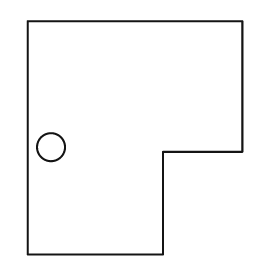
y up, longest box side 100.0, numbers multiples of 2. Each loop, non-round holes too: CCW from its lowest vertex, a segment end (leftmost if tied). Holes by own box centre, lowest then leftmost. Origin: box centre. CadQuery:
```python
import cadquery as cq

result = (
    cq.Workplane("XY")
    .moveTo(-46.0, -50.0)
    .lineTo(12.0, -50.0)
    .lineTo(12.0, -6.0)
    .lineTo(46.0, -6.0)
    .lineTo(46.0, 50.0)
    .lineTo(-46.0, 50.0)
    .close()
    .moveTo(-36.0, -4.0)
    .circle(6.0)
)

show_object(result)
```